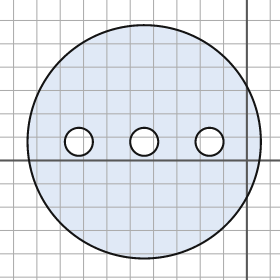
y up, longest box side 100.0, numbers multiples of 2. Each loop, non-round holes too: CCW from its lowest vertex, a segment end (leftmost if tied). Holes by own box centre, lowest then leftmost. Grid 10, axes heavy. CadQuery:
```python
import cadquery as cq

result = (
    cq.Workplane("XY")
    .moveTo(-44.0, 8.0)
    .circle(50.0)
    .moveTo(-72.0, 8.0)
    .circle(6.0)
    .moveTo(-44.0, 8.0)
    .circle(6.0)
    .moveTo(-16.0, 8.0)
    .circle(6.0)
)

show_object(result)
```